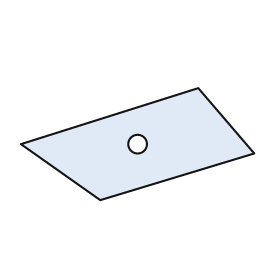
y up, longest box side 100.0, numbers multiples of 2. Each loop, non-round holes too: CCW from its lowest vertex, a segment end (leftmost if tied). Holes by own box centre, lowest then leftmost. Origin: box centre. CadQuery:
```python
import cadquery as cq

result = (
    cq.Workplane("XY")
    .moveTo(-16.0, -24.0)
    .lineTo(50.0, -4.0)
    .lineTo(26.0, 24.0)
    .lineTo(-50.0, 0.0)
    .close()
    .moveTo(0.0, 0.0)
    .circle(4.0)
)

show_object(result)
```